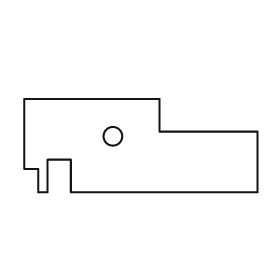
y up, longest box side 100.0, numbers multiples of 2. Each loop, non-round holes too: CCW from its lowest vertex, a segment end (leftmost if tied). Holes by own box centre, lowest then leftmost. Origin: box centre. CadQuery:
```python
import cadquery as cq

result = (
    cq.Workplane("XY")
    .moveTo(-44.0, -20.0)
    .lineTo(-40.0, -20.0)
    .lineTo(-40.0, -6.0)
    .lineTo(-30.0, -6.0)
    .lineTo(-30.0, -20.0)
    .lineTo(50.0, -20.0)
    .lineTo(50.0, 6.0)
    .lineTo(8.0, 6.0)
    .lineTo(8.0, 20.0)
    .lineTo(-50.0, 20.0)
    .lineTo(-50.0, -10.0)
    .lineTo(-44.0, -10.0)
    .close()
    .moveTo(-12.0, 4.0)
    .circle(4.0)
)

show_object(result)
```